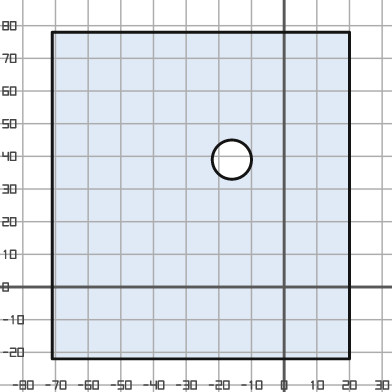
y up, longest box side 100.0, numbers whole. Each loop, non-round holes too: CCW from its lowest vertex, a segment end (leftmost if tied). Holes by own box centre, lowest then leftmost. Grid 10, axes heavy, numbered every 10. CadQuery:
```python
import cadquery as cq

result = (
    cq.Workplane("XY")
    .moveTo(-71.0, -22.0)
    .lineTo(20.0, -22.0)
    .lineTo(20.0, 78.0)
    .lineTo(-71.0, 78.0)
    .close()
    .moveTo(-16.0, 39.0)
    .circle(6.0)
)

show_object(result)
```